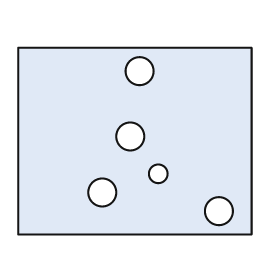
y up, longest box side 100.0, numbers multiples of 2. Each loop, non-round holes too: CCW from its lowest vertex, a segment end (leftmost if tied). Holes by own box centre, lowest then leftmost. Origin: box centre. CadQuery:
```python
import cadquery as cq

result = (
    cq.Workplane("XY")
    .moveTo(-50.0, -40.0)
    .lineTo(50.0, -40.0)
    .lineTo(50.0, 40.0)
    .lineTo(-50.0, 40.0)
    .close()
    .moveTo(36.0, -30.0)
    .circle(6.0)
    .moveTo(-14.0, -22.0)
    .circle(6.0)
    .moveTo(10.0, -14.0)
    .circle(4.0)
    .moveTo(-2.0, 2.0)
    .circle(6.0)
    .moveTo(2.0, 30.0)
    .circle(6.0)
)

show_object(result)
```